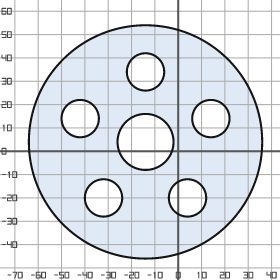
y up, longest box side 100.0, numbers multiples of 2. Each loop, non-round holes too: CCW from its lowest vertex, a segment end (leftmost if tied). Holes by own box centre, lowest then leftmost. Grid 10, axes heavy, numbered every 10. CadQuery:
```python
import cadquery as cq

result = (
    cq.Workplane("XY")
    .moveTo(-14.0, 4.0)
    .circle(50.0)
    .moveTo(-32.0, -20.0)
    .circle(8.0)
    .moveTo(4.0, -20.0)
    .circle(8.0)
    .moveTo(-14.0, 4.0)
    .circle(12.0)
    .moveTo(-42.0, 14.0)
    .circle(8.0)
    .moveTo(14.0, 14.0)
    .circle(8.0)
    .moveTo(-14.0, 34.0)
    .circle(8.0)
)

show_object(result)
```